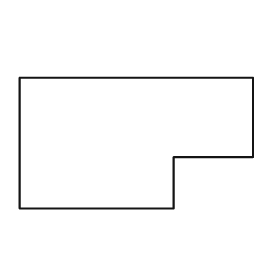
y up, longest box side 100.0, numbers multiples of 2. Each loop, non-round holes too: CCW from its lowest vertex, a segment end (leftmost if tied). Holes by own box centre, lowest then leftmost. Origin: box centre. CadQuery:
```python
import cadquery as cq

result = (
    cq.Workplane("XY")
    .moveTo(-50.0, -28.0)
    .lineTo(16.0, -28.0)
    .lineTo(16.0, -6.0)
    .lineTo(50.0, -6.0)
    .lineTo(50.0, 28.0)
    .lineTo(-50.0, 28.0)
    .close()
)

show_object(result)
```